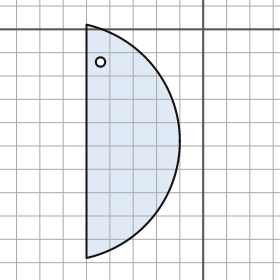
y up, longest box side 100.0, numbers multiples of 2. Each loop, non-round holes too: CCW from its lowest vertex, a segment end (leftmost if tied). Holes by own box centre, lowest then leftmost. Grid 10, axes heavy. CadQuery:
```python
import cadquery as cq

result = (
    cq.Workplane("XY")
    .moveTo(-50.0, -98.0)
    .threePointArc((-10.0, -48.0), (-50.0, 2.0))
    .close()
    .moveTo(-44.0, -14.0)
    .circle(2.0)
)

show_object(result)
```